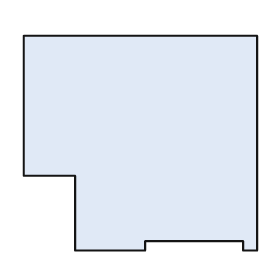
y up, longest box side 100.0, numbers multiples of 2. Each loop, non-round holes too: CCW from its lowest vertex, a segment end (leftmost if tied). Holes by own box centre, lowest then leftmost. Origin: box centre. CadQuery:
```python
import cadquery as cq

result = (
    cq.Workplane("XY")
    .moveTo(-28.0, -46.0)
    .lineTo(2.0, -46.0)
    .lineTo(2.0, -42.0)
    .lineTo(44.0, -42.0)
    .lineTo(44.0, -46.0)
    .lineTo(50.0, -46.0)
    .lineTo(50.0, 46.0)
    .lineTo(-50.0, 46.0)
    .lineTo(-50.0, -14.0)
    .lineTo(-28.0, -14.0)
    .close()
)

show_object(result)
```